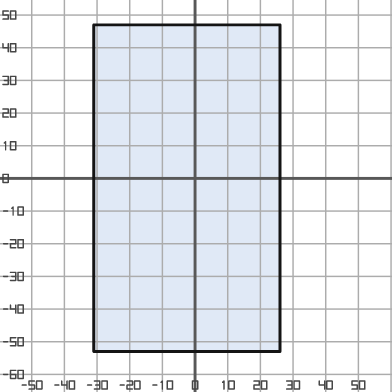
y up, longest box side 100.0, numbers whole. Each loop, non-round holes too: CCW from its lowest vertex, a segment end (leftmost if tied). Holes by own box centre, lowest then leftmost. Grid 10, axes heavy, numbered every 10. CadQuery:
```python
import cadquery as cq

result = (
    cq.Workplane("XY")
    .moveTo(-31.0, -53.0)
    .lineTo(26.0, -53.0)
    .lineTo(26.0, 47.0)
    .lineTo(-31.0, 47.0)
    .close()
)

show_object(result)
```